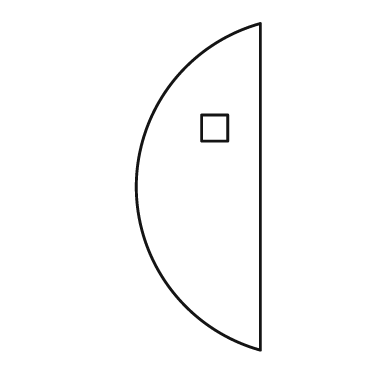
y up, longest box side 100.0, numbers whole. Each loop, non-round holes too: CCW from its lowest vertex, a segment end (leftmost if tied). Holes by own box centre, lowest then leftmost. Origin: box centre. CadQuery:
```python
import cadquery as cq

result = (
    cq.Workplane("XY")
    .moveTo(19.0, -50.0)
    .lineTo(19.0, 50.0)
    .threePointArc((-19.0, 0.0), (19.0, -50.0))
    .close()
    .moveTo(1.0, 14.0)
    .lineTo(9.0, 14.0)
    .lineTo(9.0, 22.0)
    .lineTo(1.0, 22.0)
    .close()
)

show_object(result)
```